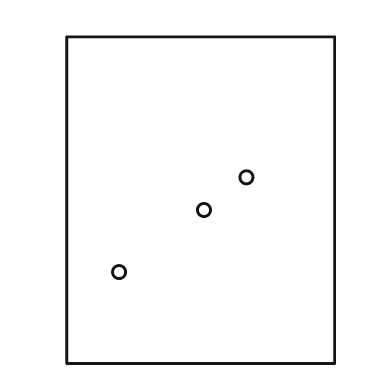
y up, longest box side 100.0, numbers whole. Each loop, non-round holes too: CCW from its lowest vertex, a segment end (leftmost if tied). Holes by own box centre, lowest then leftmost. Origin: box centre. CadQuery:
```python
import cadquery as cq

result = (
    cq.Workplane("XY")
    .moveTo(-41.0, -50.0)
    .lineTo(41.0, -50.0)
    .lineTo(41.0, 50.0)
    .lineTo(-41.0, 50.0)
    .close()
    .moveTo(-25.0, -22.0)
    .circle(2.0)
    .moveTo(1.0, -3.0)
    .circle(2.0)
    .moveTo(14.0, 7.0)
    .circle(2.0)
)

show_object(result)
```